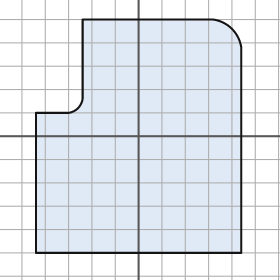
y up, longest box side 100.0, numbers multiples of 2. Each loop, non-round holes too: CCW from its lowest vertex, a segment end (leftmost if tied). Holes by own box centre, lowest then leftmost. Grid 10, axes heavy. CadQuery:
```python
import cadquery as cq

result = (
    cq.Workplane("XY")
    .moveTo(-44.0, -50.0)
    .lineTo(44.0, -50.0)
    .lineTo(44.0, 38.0)
    .threePointArc((40.0, 46.0), (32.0, 50.0))
    .lineTo(-24.0, 50.0)
    .lineTo(-24.0, 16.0)
    .threePointArc((-26.0, 12.0), (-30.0, 10.0))
    .lineTo(-44.0, 10.0)
    .close()
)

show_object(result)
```